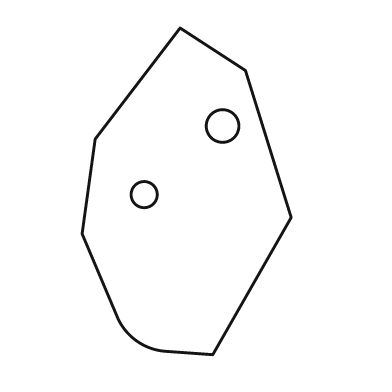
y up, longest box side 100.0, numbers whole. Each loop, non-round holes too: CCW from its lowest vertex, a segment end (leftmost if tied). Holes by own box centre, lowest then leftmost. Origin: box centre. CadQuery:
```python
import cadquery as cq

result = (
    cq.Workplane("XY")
    .moveTo(8.0, -50.0)
    .lineTo(32.0, -8.0)
    .lineTo(18.0, 37.0)
    .lineTo(-2.0, 50.0)
    .lineTo(-28.0, 16.0)
    .lineTo(-32.0, -13.0)
    .lineTo(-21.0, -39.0)
    .threePointArc((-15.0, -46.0), (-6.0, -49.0))
    .close()
    .moveTo(-13.0, -1.0)
    .circle(4.0)
    .moveTo(11.0, 20.0)
    .circle(5.0)
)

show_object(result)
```